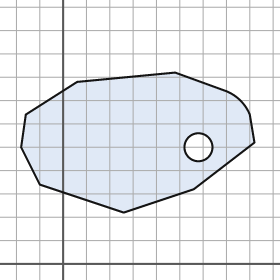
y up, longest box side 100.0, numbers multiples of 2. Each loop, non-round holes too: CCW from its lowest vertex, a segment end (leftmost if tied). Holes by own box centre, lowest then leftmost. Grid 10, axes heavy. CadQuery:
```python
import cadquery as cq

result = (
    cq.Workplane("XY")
    .moveTo(26.0, 22.0)
    .lineTo(56.0, 32.0)
    .lineTo(82.0, 52.0)
    .lineTo(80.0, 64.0)
    .threePointArc((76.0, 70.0), (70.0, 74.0))
    .lineTo(48.0, 82.0)
    .lineTo(6.0, 78.0)
    .lineTo(-16.0, 64.0)
    .lineTo(-18.0, 50.0)
    .lineTo(-10.0, 34.0)
    .close()
    .moveTo(58.0, 50.0)
    .circle(6.0)
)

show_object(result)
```